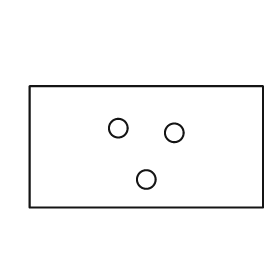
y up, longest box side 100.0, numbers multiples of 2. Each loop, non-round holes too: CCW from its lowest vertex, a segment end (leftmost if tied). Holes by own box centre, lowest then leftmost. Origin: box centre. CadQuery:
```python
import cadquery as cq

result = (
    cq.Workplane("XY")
    .moveTo(-50.0, -26.0)
    .lineTo(50.0, -26.0)
    .lineTo(50.0, 26.0)
    .lineTo(-50.0, 26.0)
    .close()
    .moveTo(0.0, -14.0)
    .circle(4.0)
    .moveTo(12.0, 6.0)
    .circle(4.0)
    .moveTo(-12.0, 8.0)
    .circle(4.0)
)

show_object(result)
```